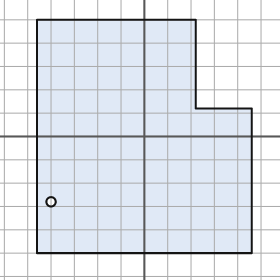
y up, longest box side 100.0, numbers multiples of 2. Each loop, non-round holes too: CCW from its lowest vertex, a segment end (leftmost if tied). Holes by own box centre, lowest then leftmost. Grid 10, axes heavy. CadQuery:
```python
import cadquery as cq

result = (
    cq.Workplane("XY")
    .moveTo(-46.0, -50.0)
    .lineTo(46.0, -50.0)
    .lineTo(46.0, 12.0)
    .lineTo(22.0, 12.0)
    .lineTo(22.0, 50.0)
    .lineTo(-46.0, 50.0)
    .close()
    .moveTo(-40.0, -28.0)
    .circle(2.0)
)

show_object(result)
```